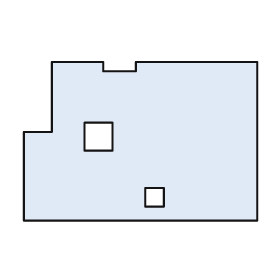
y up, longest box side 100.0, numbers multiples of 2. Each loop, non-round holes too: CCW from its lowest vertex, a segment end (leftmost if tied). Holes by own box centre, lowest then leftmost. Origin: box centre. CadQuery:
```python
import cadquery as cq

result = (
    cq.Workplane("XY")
    .moveTo(-50.0, -34.0)
    .lineTo(50.0, -34.0)
    .lineTo(50.0, 34.0)
    .lineTo(-2.0, 34.0)
    .lineTo(-2.0, 30.0)
    .lineTo(-16.0, 30.0)
    .lineTo(-16.0, 34.0)
    .lineTo(-38.0, 34.0)
    .lineTo(-38.0, 4.0)
    .lineTo(-50.0, 4.0)
    .close()
    .moveTo(2.0, -28.0)
    .lineTo(10.0, -28.0)
    .lineTo(10.0, -20.0)
    .lineTo(2.0, -20.0)
    .close()
    .moveTo(-24.0, -4.0)
    .lineTo(-12.0, -4.0)
    .lineTo(-12.0, 8.0)
    .lineTo(-24.0, 8.0)
    .close()
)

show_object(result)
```